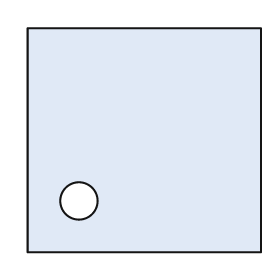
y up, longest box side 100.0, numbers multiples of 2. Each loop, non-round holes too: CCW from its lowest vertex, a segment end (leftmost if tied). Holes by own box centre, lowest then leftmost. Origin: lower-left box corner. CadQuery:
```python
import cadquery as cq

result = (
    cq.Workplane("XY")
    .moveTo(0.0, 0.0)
    .lineTo(100.0, 0.0)
    .lineTo(100.0, 96.0)
    .lineTo(0.0, 96.0)
    .close()
    .moveTo(22.0, 22.0)
    .circle(8.0)
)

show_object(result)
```